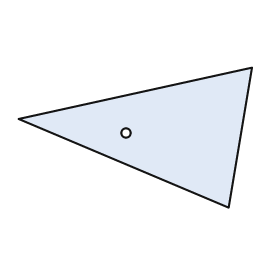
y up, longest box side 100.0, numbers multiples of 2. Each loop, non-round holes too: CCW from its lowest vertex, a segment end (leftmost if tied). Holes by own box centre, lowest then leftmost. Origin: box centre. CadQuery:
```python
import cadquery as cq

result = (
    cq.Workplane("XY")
    .moveTo(40.0, -30.0)
    .lineTo(50.0, 30.0)
    .lineTo(-50.0, 8.0)
    .close()
    .moveTo(-4.0, 2.0)
    .circle(2.0)
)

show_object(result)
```